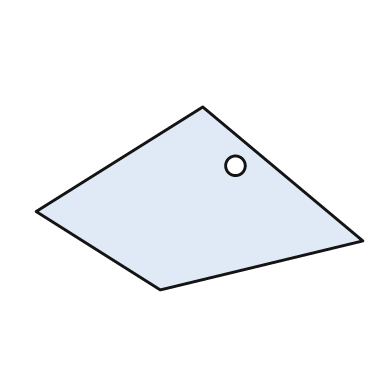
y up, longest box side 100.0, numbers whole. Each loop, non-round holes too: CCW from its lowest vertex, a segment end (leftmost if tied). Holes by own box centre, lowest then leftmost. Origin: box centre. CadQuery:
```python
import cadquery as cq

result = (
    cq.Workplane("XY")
    .moveTo(-12.0, -28.0)
    .lineTo(50.0, -13.0)
    .lineTo(1.0, 28.0)
    .lineTo(-50.0, -4.0)
    .close()
    .moveTo(11.0, 10.0)
    .circle(3.0)
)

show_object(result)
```